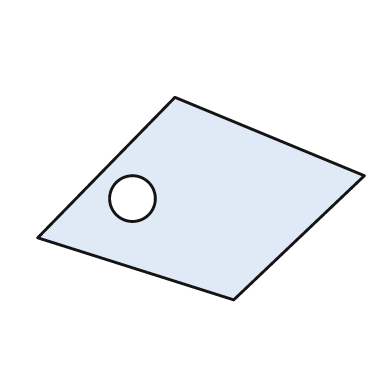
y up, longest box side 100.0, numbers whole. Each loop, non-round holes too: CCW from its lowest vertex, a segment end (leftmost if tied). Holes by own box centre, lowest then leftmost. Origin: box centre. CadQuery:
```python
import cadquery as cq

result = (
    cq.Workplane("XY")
    .moveTo(10.0, -31.0)
    .lineTo(50.0, 7.0)
    .lineTo(-8.0, 31.0)
    .lineTo(-50.0, -12.0)
    .close()
    .moveTo(-21.0, 0.0)
    .circle(7.0)
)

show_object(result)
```